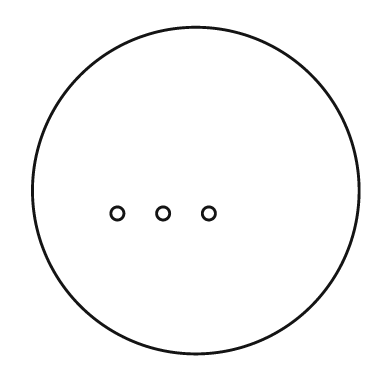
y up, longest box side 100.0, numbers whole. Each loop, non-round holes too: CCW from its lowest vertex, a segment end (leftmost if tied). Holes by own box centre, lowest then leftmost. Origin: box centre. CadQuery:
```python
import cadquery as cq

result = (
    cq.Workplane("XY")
    .moveTo(0.0, 0.0)
    .circle(50.0)
    .moveTo(-24.0, -7.0)
    .circle(2.0)
    .moveTo(-10.0, -7.0)
    .circle(2.0)
    .moveTo(4.0, -7.0)
    .circle(2.0)
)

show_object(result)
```